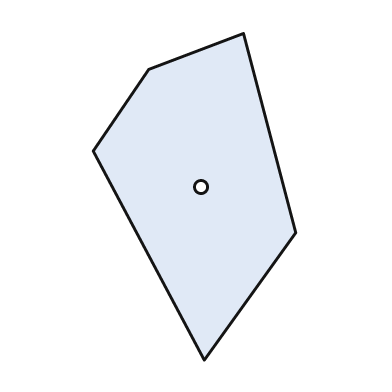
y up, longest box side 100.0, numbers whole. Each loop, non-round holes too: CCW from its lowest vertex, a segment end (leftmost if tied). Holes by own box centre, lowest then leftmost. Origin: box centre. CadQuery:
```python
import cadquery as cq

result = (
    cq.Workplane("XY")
    .moveTo(3.0, -50.0)
    .lineTo(31.0, -11.0)
    .lineTo(15.0, 50.0)
    .lineTo(-14.0, 39.0)
    .lineTo(-31.0, 14.0)
    .close()
    .moveTo(2.0, 3.0)
    .circle(2.0)
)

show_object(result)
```